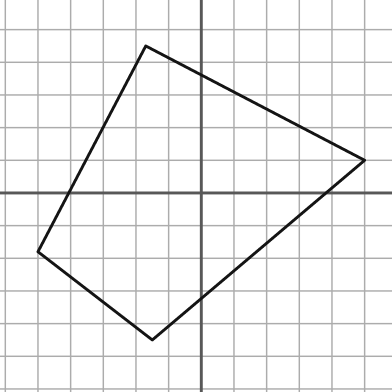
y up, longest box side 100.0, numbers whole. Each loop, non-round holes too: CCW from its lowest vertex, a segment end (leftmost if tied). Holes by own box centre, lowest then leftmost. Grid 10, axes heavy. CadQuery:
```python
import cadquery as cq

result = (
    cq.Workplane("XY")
    .moveTo(-15.0, -45.0)
    .lineTo(50.0, 10.0)
    .lineTo(-17.0, 45.0)
    .lineTo(-50.0, -18.0)
    .close()
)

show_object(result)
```